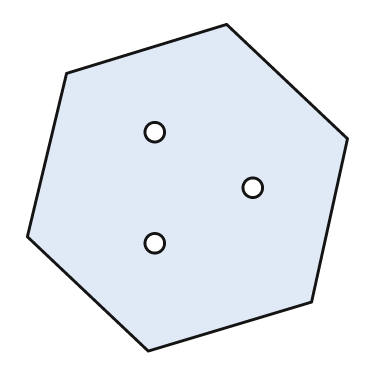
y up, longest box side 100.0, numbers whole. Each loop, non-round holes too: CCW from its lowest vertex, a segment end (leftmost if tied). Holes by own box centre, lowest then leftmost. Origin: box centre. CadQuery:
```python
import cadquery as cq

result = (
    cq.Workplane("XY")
    .moveTo(-12.0, -50.0)
    .lineTo(38.0, -35.0)
    .lineTo(49.0, 15.0)
    .lineTo(12.0, 50.0)
    .lineTo(-37.0, 35.0)
    .lineTo(-49.0, -15.0)
    .close()
    .moveTo(-10.0, -17.0)
    .circle(3.0)
    .moveTo(20.0, 0.0)
    .circle(3.0)
    .moveTo(-10.0, 17.0)
    .circle(3.0)
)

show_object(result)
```